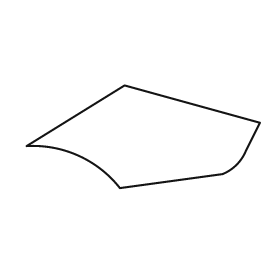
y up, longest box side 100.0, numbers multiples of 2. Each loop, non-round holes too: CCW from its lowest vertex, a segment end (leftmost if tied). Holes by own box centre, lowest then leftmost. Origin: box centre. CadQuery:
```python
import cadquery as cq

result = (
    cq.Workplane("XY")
    .moveTo(-10.0, -22.0)
    .lineTo(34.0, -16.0)
    .threePointArc((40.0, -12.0), (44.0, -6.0))
    .lineTo(50.0, 6.0)
    .lineTo(-8.0, 22.0)
    .lineTo(-50.0, -4.0)
    .threePointArc((-28.0, -8.0), (-10.0, -22.0))
    .close()
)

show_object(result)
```